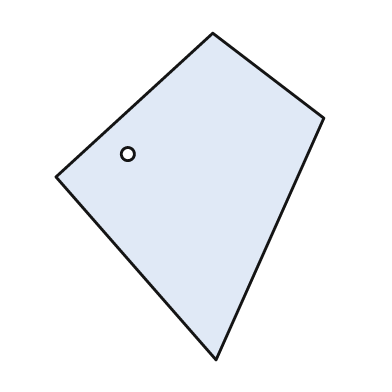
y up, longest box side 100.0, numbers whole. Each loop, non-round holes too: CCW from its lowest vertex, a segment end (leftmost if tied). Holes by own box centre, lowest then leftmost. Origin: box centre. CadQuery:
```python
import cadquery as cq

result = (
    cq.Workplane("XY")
    .moveTo(8.0, -50.0)
    .lineTo(41.0, 24.0)
    .lineTo(7.0, 50.0)
    .lineTo(-41.0, 6.0)
    .close()
    .moveTo(-19.0, 13.0)
    .circle(2.0)
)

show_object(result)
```